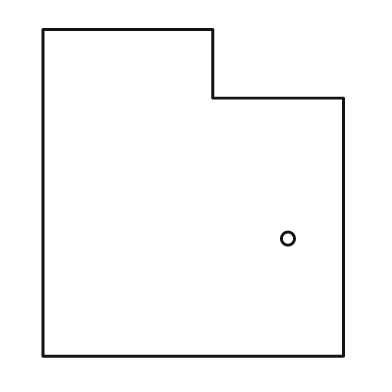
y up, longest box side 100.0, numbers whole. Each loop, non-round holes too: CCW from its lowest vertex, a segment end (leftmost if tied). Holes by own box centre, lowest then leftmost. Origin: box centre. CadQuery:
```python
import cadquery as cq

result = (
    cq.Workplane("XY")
    .moveTo(-46.0, -50.0)
    .lineTo(46.0, -50.0)
    .lineTo(46.0, 29.0)
    .lineTo(6.0, 29.0)
    .lineTo(6.0, 50.0)
    .lineTo(-46.0, 50.0)
    .close()
    .moveTo(29.0, -14.0)
    .circle(2.0)
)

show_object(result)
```